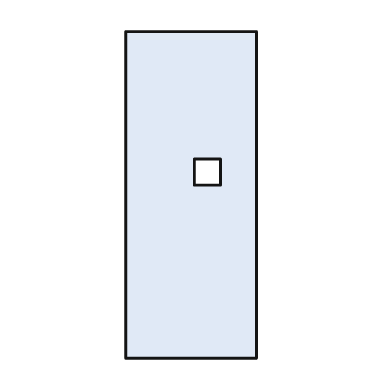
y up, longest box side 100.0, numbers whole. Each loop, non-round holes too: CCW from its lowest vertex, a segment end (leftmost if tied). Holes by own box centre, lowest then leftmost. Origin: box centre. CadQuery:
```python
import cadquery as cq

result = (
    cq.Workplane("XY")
    .moveTo(-20.0, -50.0)
    .lineTo(20.0, -50.0)
    .lineTo(20.0, 50.0)
    .lineTo(-20.0, 50.0)
    .close()
    .moveTo(1.0, 3.0)
    .lineTo(9.0, 3.0)
    .lineTo(9.0, 11.0)
    .lineTo(1.0, 11.0)
    .close()
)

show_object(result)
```